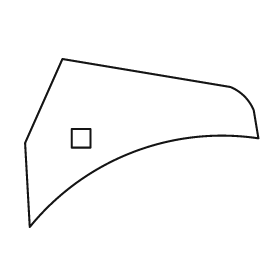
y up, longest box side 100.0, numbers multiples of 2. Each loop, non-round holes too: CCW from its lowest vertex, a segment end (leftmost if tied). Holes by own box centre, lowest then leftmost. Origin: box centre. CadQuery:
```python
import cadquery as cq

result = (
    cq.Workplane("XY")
    .moveTo(-48.0, -36.0)
    .threePointArc((-4.0, -4.0), (50.0, 2.0))
    .lineTo(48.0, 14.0)
    .threePointArc((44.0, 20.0), (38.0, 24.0))
    .lineTo(-34.0, 36.0)
    .lineTo(-50.0, 0.0)
    .close()
    .moveTo(-30.0, -2.0)
    .lineTo(-22.0, -2.0)
    .lineTo(-22.0, 6.0)
    .lineTo(-30.0, 6.0)
    .close()
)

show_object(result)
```